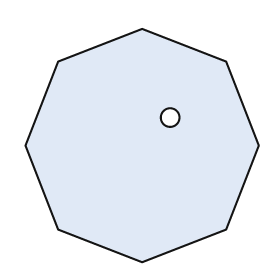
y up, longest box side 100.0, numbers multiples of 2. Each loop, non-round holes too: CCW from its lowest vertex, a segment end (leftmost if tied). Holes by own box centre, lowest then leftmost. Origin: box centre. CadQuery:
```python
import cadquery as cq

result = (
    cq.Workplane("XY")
    .moveTo(0.0, -50.0)
    .lineTo(36.0, -36.0)
    .lineTo(50.0, 0.0)
    .lineTo(36.0, 36.0)
    .lineTo(0.0, 50.0)
    .lineTo(-36.0, 36.0)
    .lineTo(-50.0, 0.0)
    .lineTo(-36.0, -36.0)
    .close()
    .moveTo(12.0, 12.0)
    .circle(4.0)
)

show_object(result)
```